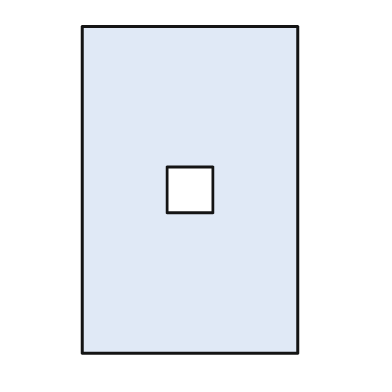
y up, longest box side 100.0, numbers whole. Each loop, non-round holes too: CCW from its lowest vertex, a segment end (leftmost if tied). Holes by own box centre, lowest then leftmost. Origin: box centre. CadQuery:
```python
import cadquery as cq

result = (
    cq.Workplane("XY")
    .moveTo(-33.0, -50.0)
    .lineTo(33.0, -50.0)
    .lineTo(33.0, 50.0)
    .lineTo(-33.0, 50.0)
    .close()
    .moveTo(-7.0, -7.0)
    .lineTo(7.0, -7.0)
    .lineTo(7.0, 7.0)
    .lineTo(-7.0, 7.0)
    .close()
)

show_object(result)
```